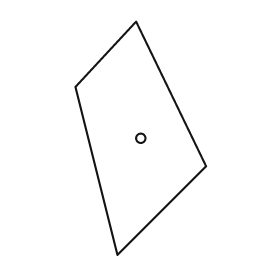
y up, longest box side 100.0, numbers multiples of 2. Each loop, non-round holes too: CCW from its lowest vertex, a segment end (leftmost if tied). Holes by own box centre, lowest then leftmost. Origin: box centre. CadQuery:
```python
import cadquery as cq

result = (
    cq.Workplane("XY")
    .moveTo(-10.0, -50.0)
    .lineTo(28.0, -12.0)
    .lineTo(-2.0, 50.0)
    .lineTo(-28.0, 22.0)
    .close()
    .moveTo(0.0, 0.0)
    .circle(2.0)
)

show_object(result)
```